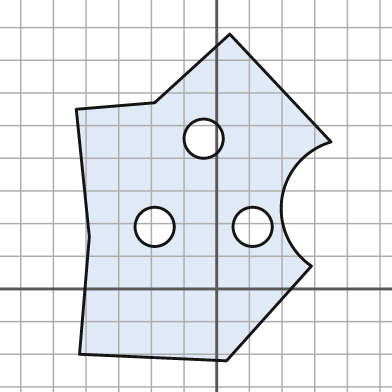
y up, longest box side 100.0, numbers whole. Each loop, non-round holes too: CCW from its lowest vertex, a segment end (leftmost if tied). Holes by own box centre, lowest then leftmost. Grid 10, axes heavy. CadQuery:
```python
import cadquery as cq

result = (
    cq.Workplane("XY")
    .moveTo(3.0, -22.0)
    .lineTo(29.0, 7.0)
    .threePointArc((20.0, 28.0), (35.0, 45.0))
    .lineTo(4.0, 78.0)
    .lineTo(-19.0, 57.0)
    .lineTo(-43.0, 55.0)
    .lineTo(-39.0, 16.0)
    .lineTo(-42.0, -20.0)
    .close()
    .moveTo(-19.0, 19.0)
    .circle(6.0)
    .moveTo(11.0, 19.0)
    .circle(6.0)
    .moveTo(-4.0, 46.0)
    .circle(6.0)
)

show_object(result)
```